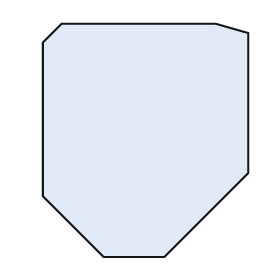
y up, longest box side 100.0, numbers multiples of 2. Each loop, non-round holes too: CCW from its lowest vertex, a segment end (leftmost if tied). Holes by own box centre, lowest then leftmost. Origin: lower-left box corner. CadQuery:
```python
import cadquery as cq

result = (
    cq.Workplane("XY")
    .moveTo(26.0, 0.0)
    .lineTo(52.0, 0.0)
    .lineTo(88.0, 36.0)
    .lineTo(88.0, 96.0)
    .lineTo(74.0, 100.0)
    .lineTo(8.0, 100.0)
    .lineTo(0.0, 92.0)
    .lineTo(0.0, 26.0)
    .close()
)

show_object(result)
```